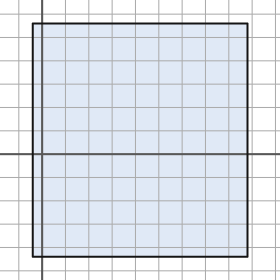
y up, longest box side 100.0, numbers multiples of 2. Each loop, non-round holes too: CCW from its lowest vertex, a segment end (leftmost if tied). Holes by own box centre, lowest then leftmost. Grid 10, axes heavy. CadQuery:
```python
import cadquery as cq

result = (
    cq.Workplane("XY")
    .moveTo(-4.0, -44.0)
    .lineTo(88.0, -44.0)
    .lineTo(88.0, 56.0)
    .lineTo(-4.0, 56.0)
    .close()
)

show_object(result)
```